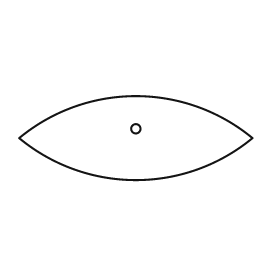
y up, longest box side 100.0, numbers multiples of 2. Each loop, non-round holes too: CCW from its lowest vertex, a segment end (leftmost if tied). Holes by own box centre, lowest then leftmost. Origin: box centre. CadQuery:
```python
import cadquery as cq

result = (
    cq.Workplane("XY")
    .moveTo(-50.0, 0.0)
    .threePointArc((0.0, -18.0), (50.0, 0.0))
    .threePointArc((0.0, 18.0), (-50.0, 0.0))
    .close()
    .moveTo(0.0, 4.0)
    .circle(2.0)
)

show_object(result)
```